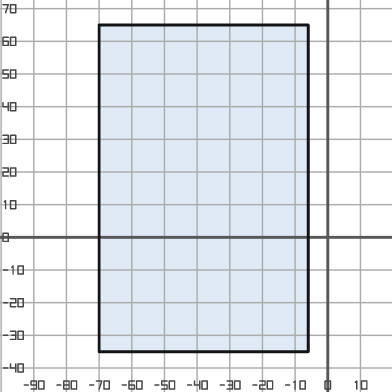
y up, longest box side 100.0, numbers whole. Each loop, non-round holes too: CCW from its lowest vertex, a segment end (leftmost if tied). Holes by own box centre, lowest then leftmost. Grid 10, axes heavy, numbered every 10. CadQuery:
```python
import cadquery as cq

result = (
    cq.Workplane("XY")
    .moveTo(-70.0, -35.0)
    .lineTo(-6.0, -35.0)
    .lineTo(-6.0, 65.0)
    .lineTo(-70.0, 65.0)
    .close()
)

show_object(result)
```